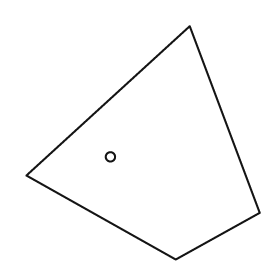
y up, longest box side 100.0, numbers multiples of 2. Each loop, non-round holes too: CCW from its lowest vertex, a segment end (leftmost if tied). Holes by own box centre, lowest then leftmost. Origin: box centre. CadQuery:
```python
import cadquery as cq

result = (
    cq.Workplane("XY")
    .moveTo(14.0, -50.0)
    .lineTo(50.0, -30.0)
    .lineTo(20.0, 50.0)
    .lineTo(-50.0, -14.0)
    .close()
    .moveTo(-14.0, -6.0)
    .circle(2.0)
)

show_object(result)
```